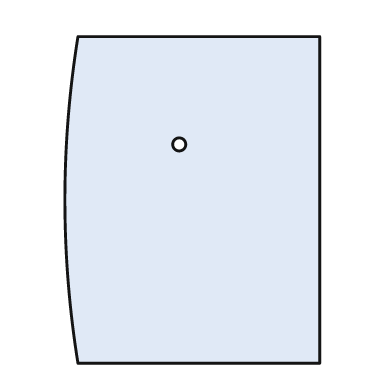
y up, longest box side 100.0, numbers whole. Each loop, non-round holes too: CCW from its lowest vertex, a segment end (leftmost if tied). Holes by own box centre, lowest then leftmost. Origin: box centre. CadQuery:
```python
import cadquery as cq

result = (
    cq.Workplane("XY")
    .moveTo(-35.0, -50.0)
    .lineTo(39.0, -50.0)
    .lineTo(39.0, 50.0)
    .lineTo(-35.0, 50.0)
    .threePointArc((-39.0, 0.0), (-35.0, -50.0))
    .close()
    .moveTo(-4.0, 17.0)
    .circle(2.0)
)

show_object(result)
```